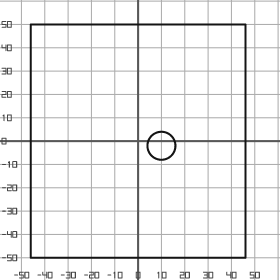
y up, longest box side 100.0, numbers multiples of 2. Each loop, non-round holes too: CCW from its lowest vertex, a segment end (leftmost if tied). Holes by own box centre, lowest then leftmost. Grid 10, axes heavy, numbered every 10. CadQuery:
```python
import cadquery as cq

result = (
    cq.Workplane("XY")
    .moveTo(-46.0, -50.0)
    .lineTo(46.0, -50.0)
    .lineTo(46.0, 50.0)
    .lineTo(-46.0, 50.0)
    .close()
    .moveTo(10.0, -2.0)
    .circle(6.0)
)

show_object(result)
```